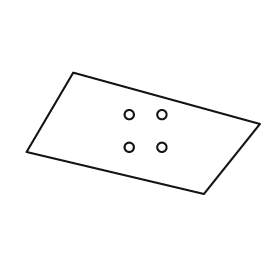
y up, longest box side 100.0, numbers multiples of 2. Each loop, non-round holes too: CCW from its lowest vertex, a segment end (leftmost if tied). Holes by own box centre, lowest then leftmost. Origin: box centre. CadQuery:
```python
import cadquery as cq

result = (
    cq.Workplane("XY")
    .moveTo(26.0, -26.0)
    .lineTo(50.0, 4.0)
    .lineTo(-30.0, 26.0)
    .lineTo(-50.0, -8.0)
    .close()
    .moveTo(-6.0, -6.0)
    .circle(2.0)
    .moveTo(8.0, -6.0)
    .circle(2.0)
    .moveTo(-6.0, 8.0)
    .circle(2.0)
    .moveTo(8.0, 8.0)
    .circle(2.0)
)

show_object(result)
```